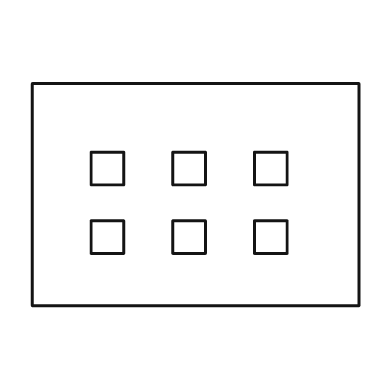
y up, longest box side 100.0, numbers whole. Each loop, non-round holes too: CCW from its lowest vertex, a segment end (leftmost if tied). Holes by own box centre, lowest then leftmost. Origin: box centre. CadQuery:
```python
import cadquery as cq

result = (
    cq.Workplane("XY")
    .moveTo(-50.0, -34.0)
    .lineTo(50.0, -34.0)
    .lineTo(50.0, 34.0)
    .lineTo(-50.0, 34.0)
    .close()
    .moveTo(-32.0, -18.0)
    .lineTo(-22.0, -18.0)
    .lineTo(-22.0, -8.0)
    .lineTo(-32.0, -8.0)
    .close()
    .moveTo(-7.0, -18.0)
    .lineTo(3.0, -18.0)
    .lineTo(3.0, -8.0)
    .lineTo(-7.0, -8.0)
    .close()
    .moveTo(18.0, -18.0)
    .lineTo(28.0, -18.0)
    .lineTo(28.0, -8.0)
    .lineTo(18.0, -8.0)
    .close()
    .moveTo(-32.0, 3.0)
    .lineTo(-22.0, 3.0)
    .lineTo(-22.0, 13.0)
    .lineTo(-32.0, 13.0)
    .close()
    .moveTo(-7.0, 3.0)
    .lineTo(3.0, 3.0)
    .lineTo(3.0, 13.0)
    .lineTo(-7.0, 13.0)
    .close()
    .moveTo(18.0, 3.0)
    .lineTo(28.0, 3.0)
    .lineTo(28.0, 13.0)
    .lineTo(18.0, 13.0)
    .close()
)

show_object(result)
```